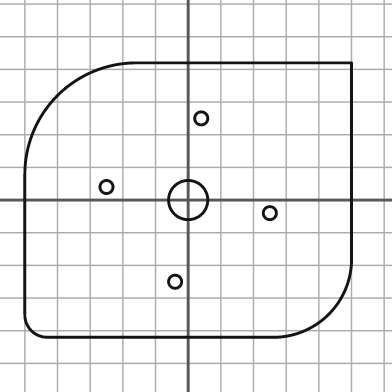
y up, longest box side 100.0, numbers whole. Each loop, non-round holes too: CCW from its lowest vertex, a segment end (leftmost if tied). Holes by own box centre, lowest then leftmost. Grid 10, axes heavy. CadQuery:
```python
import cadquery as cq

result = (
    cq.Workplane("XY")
    .moveTo(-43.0, -42.0)
    .lineTo(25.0, -42.0)
    .threePointArc((43.0, -35.0), (50.0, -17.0))
    .lineTo(50.0, 42.0)
    .lineTo(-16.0, 42.0)
    .threePointArc((-40.0, 32.0), (-50.0, 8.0))
    .lineTo(-50.0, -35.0)
    .threePointArc((-48.0, -40.0), (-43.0, -42.0))
    .close()
    .moveTo(-4.0, -25.0)
    .circle(2.0)
    .moveTo(25.0, -4.0)
    .circle(2.0)
    .moveTo(0.0, 0.0)
    .circle(6.0)
    .moveTo(-25.0, 4.0)
    .circle(2.0)
    .moveTo(4.0, 25.0)
    .circle(2.0)
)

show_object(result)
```